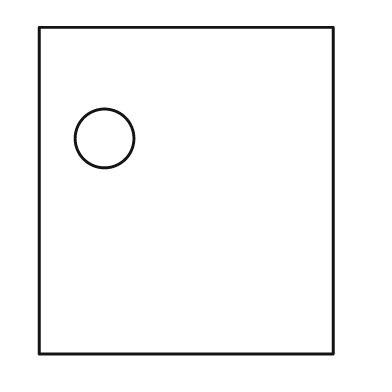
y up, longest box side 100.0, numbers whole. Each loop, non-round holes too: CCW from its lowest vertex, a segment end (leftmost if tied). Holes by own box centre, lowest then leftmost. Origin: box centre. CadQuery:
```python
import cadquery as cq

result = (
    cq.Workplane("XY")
    .moveTo(-45.0, -50.0)
    .lineTo(45.0, -50.0)
    .lineTo(45.0, 50.0)
    .lineTo(-45.0, 50.0)
    .close()
    .moveTo(-25.0, 16.0)
    .circle(9.0)
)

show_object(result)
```